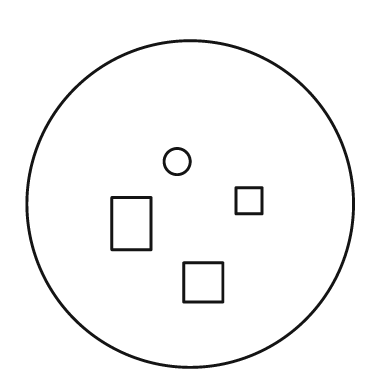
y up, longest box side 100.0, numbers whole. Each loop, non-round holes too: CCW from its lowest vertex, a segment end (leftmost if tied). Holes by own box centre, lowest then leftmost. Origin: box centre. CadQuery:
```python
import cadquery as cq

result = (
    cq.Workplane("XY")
    .moveTo(0.0, 0.0)
    .circle(50.0)
    .moveTo(-2.0, -30.0)
    .lineTo(10.0, -30.0)
    .lineTo(10.0, -18.0)
    .lineTo(-2.0, -18.0)
    .close()
    .moveTo(-24.0, -14.0)
    .lineTo(-12.0, -14.0)
    .lineTo(-12.0, 2.0)
    .lineTo(-24.0, 2.0)
    .close()
    .moveTo(14.0, -3.0)
    .lineTo(22.0, -3.0)
    .lineTo(22.0, 5.0)
    .lineTo(14.0, 5.0)
    .close()
    .moveTo(-4.0, 13.0)
    .circle(4.0)
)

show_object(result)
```